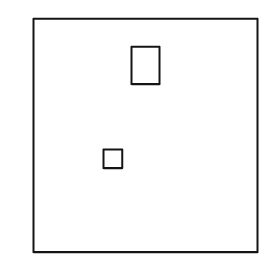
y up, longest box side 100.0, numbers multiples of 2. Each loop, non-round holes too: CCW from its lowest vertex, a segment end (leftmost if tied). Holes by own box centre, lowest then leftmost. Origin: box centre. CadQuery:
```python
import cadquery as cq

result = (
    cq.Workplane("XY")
    .moveTo(-48.0, -50.0)
    .lineTo(48.0, -50.0)
    .lineTo(48.0, 50.0)
    .lineTo(-48.0, 50.0)
    .close()
    .moveTo(-18.0, -14.0)
    .lineTo(-10.0, -14.0)
    .lineTo(-10.0, -6.0)
    .lineTo(-18.0, -6.0)
    .close()
    .moveTo(-6.0, 22.0)
    .lineTo(6.0, 22.0)
    .lineTo(6.0, 38.0)
    .lineTo(-6.0, 38.0)
    .close()
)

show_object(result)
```